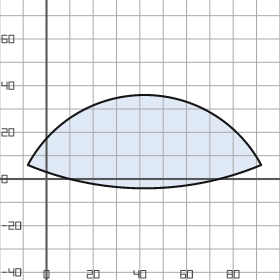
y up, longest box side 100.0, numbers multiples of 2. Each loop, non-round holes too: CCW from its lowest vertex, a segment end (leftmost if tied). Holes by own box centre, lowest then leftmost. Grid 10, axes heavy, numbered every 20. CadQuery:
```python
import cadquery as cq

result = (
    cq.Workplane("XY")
    .moveTo(-8.0, 6.0)
    .threePointArc((42.0, -4.0), (92.0, 6.0))
    .threePointArc((42.0, 36.0), (-8.0, 6.0))
    .close()
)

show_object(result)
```